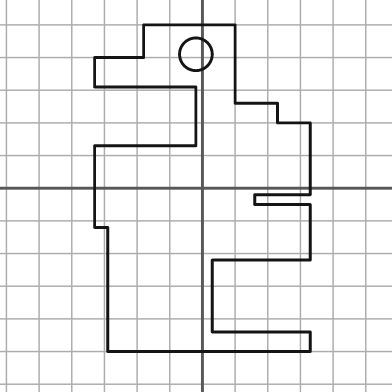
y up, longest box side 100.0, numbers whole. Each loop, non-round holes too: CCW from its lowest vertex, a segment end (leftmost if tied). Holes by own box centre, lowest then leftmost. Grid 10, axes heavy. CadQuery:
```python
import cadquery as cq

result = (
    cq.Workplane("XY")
    .moveTo(-29.0, -50.0)
    .lineTo(33.0, -50.0)
    .lineTo(33.0, -44.0)
    .lineTo(3.0, -44.0)
    .lineTo(3.0, -22.0)
    .lineTo(33.0, -22.0)
    .lineTo(33.0, -5.0)
    .lineTo(16.0, -5.0)
    .lineTo(16.0, -2.0)
    .lineTo(33.0, -2.0)
    .lineTo(33.0, 20.0)
    .lineTo(23.0, 20.0)
    .lineTo(23.0, 26.0)
    .lineTo(10.0, 26.0)
    .lineTo(10.0, 50.0)
    .lineTo(-18.0, 50.0)
    .lineTo(-18.0, 40.0)
    .lineTo(-33.0, 40.0)
    .lineTo(-33.0, 31.0)
    .lineTo(-2.0, 31.0)
    .lineTo(-2.0, 13.0)
    .lineTo(-33.0, 13.0)
    .lineTo(-33.0, -12.0)
    .lineTo(-29.0, -12.0)
    .close()
    .moveTo(-2.0, 41.0)
    .circle(5.0)
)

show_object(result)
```